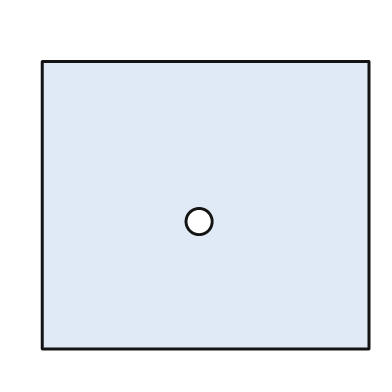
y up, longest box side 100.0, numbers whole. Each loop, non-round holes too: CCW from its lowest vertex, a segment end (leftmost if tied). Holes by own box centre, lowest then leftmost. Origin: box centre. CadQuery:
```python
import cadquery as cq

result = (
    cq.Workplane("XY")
    .moveTo(-50.0, -44.0)
    .lineTo(50.0, -44.0)
    .lineTo(50.0, 44.0)
    .lineTo(-50.0, 44.0)
    .close()
    .moveTo(-2.0, -5.0)
    .circle(4.0)
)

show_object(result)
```